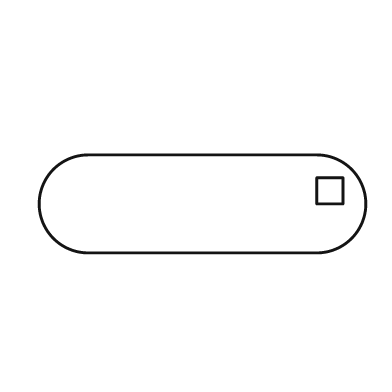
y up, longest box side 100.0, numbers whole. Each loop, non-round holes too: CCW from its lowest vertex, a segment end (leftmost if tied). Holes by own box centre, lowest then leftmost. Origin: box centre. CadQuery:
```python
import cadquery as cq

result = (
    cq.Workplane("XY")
    .moveTo(-35.0, -15.0)
    .lineTo(35.0, -15.0)
    .threePointArc((50.0, 0.0), (35.0, 15.0))
    .lineTo(-35.0, 15.0)
    .threePointArc((-50.0, 0.0), (-35.0, -15.0))
    .close()
    .moveTo(35.0, 0.0)
    .lineTo(43.0, 0.0)
    .lineTo(43.0, 8.0)
    .lineTo(35.0, 8.0)
    .close()
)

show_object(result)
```